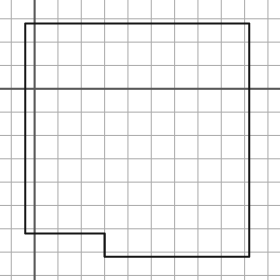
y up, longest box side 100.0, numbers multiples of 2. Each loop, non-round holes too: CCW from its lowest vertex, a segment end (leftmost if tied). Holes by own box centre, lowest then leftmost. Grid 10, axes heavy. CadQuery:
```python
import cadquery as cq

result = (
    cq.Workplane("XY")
    .moveTo(30.0, -72.0)
    .lineTo(92.0, -72.0)
    .lineTo(92.0, 28.0)
    .lineTo(-4.0, 28.0)
    .lineTo(-4.0, -62.0)
    .lineTo(30.0, -62.0)
    .close()
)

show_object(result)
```